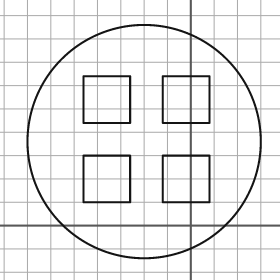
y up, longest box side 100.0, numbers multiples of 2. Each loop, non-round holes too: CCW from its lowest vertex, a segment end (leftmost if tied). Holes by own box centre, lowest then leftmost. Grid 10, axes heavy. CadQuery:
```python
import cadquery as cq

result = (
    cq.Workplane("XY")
    .moveTo(-20.0, 36.0)
    .circle(50.0)
    .moveTo(-46.0, 10.0)
    .lineTo(-26.0, 10.0)
    .lineTo(-26.0, 30.0)
    .lineTo(-46.0, 30.0)
    .close()
    .moveTo(-12.0, 10.0)
    .lineTo(8.0, 10.0)
    .lineTo(8.0, 30.0)
    .lineTo(-12.0, 30.0)
    .close()
    .moveTo(-46.0, 44.0)
    .lineTo(-26.0, 44.0)
    .lineTo(-26.0, 64.0)
    .lineTo(-46.0, 64.0)
    .close()
    .moveTo(-12.0, 44.0)
    .lineTo(8.0, 44.0)
    .lineTo(8.0, 64.0)
    .lineTo(-12.0, 64.0)
    .close()
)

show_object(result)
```